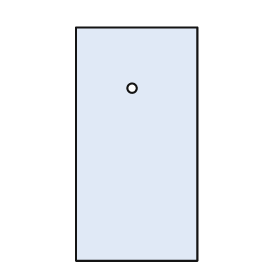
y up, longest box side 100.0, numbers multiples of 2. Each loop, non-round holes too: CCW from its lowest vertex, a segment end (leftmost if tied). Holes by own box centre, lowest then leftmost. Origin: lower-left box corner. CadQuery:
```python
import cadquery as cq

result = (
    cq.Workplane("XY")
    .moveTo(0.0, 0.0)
    .lineTo(52.0, 0.0)
    .lineTo(52.0, 100.0)
    .lineTo(0.0, 100.0)
    .close()
    .moveTo(24.0, 74.0)
    .circle(2.0)
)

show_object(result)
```